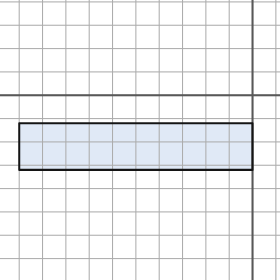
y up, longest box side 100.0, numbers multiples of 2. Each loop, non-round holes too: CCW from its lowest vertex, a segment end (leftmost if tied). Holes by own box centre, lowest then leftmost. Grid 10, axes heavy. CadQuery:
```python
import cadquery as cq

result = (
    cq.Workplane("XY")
    .moveTo(-100.0, -32.0)
    .lineTo(0.0, -32.0)
    .lineTo(0.0, -12.0)
    .lineTo(-100.0, -12.0)
    .close()
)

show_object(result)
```